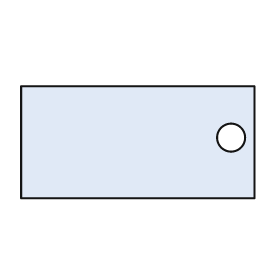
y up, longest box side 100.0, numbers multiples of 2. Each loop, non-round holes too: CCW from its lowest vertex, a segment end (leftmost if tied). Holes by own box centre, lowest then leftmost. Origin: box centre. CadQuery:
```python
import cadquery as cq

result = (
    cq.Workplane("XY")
    .moveTo(-50.0, -24.0)
    .lineTo(50.0, -24.0)
    .lineTo(50.0, 24.0)
    .lineTo(-50.0, 24.0)
    .close()
    .moveTo(40.0, 2.0)
    .circle(6.0)
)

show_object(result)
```